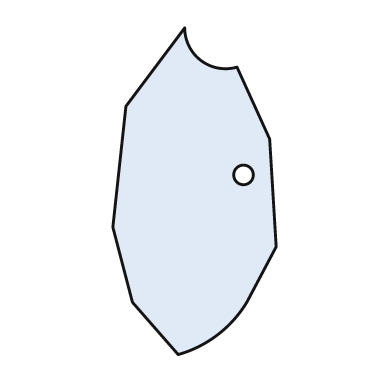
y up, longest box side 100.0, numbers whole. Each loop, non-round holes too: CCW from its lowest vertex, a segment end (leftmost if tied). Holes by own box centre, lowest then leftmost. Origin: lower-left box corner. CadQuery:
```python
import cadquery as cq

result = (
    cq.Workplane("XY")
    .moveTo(20.0, 0.0)
    .threePointArc((32.0, 6.0), (41.0, 16.0))
    .lineTo(50.0, 33.0)
    .lineTo(48.0, 66.0)
    .lineTo(38.0, 88.0)
    .threePointArc((27.0, 90.0), (22.0, 100.0))
    .lineTo(4.0, 76.0)
    .lineTo(0.0, 39.0)
    .lineTo(6.0, 16.0)
    .close()
    .moveTo(40.0, 55.0)
    .circle(3.0)
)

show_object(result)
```